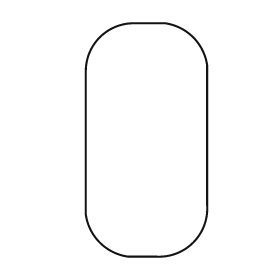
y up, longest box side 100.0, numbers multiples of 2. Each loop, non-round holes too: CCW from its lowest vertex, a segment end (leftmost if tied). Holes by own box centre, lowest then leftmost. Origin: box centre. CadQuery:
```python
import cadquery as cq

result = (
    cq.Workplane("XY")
    .moveTo(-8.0, -50.0)
    .lineTo(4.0, -50.0)
    .threePointArc((20.0, -44.0), (26.0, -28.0))
    .lineTo(26.0, 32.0)
    .threePointArc((20.0, 44.0), (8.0, 50.0))
    .lineTo(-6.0, 50.0)
    .threePointArc((-20.0, 44.0), (-26.0, 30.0))
    .lineTo(-26.0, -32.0)
    .threePointArc((-20.0, -44.0), (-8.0, -50.0))
    .close()
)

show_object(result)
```